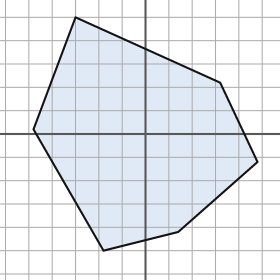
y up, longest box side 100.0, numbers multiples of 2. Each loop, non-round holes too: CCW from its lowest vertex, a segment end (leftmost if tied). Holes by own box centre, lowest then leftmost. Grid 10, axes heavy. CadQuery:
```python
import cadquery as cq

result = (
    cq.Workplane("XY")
    .moveTo(-18.0, -50.0)
    .lineTo(14.0, -42.0)
    .lineTo(48.0, -12.0)
    .lineTo(32.0, 22.0)
    .lineTo(-30.0, 50.0)
    .lineTo(-48.0, 2.0)
    .close()
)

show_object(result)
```